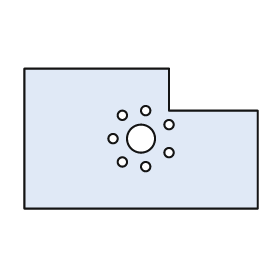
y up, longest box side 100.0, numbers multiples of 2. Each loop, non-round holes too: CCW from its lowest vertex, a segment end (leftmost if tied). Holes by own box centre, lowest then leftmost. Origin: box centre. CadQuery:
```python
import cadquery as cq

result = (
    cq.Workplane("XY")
    .moveTo(-50.0, -30.0)
    .lineTo(50.0, -30.0)
    .lineTo(50.0, 12.0)
    .lineTo(12.0, 12.0)
    .lineTo(12.0, 30.0)
    .lineTo(-50.0, 30.0)
    .close()
    .moveTo(2.0, -12.0)
    .circle(2.0)
    .moveTo(-8.0, -10.0)
    .circle(2.0)
    .moveTo(12.0, -6.0)
    .circle(2.0)
    .moveTo(-12.0, 0.0)
    .circle(2.0)
    .moveTo(0.0, 0.0)
    .circle(6.0)
    .moveTo(12.0, 6.0)
    .circle(2.0)
    .moveTo(-8.0, 10.0)
    .circle(2.0)
    .moveTo(2.0, 12.0)
    .circle(2.0)
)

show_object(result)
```